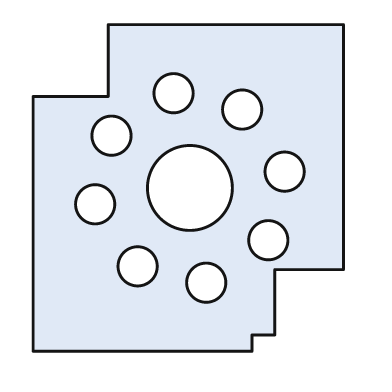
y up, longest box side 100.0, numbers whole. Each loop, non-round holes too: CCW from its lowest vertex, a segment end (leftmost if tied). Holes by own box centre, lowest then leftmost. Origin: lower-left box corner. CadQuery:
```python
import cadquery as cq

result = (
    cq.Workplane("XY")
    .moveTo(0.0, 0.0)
    .lineTo(67.0, 0.0)
    .lineTo(67.0, 5.0)
    .lineTo(74.0, 5.0)
    .lineTo(74.0, 25.0)
    .lineTo(95.0, 25.0)
    .lineTo(95.0, 100.0)
    .lineTo(23.0, 100.0)
    .lineTo(23.0, 78.0)
    .lineTo(0.0, 78.0)
    .close()
    .moveTo(53.0, 21.0)
    .circle(6.0)
    .moveTo(32.0, 26.0)
    .circle(6.0)
    .moveTo(72.0, 34.0)
    .circle(6.0)
    .moveTo(19.0, 45.0)
    .circle(6.0)
    .moveTo(48.0, 50.0)
    .circle(13.0)
    .moveTo(77.0, 55.0)
    .circle(6.0)
    .moveTo(24.0, 66.0)
    .circle(6.0)
    .moveTo(64.0, 74.0)
    .circle(6.0)
    .moveTo(43.0, 79.0)
    .circle(6.0)
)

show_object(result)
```